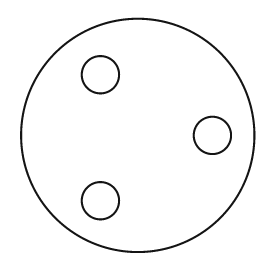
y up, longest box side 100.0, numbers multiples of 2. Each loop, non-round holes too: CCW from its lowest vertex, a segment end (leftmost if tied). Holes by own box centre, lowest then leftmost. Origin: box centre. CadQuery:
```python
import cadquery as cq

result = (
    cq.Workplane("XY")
    .moveTo(0.0, 0.0)
    .circle(50.0)
    .moveTo(-16.0, -28.0)
    .circle(8.0)
    .moveTo(32.0, 0.0)
    .circle(8.0)
    .moveTo(-16.0, 26.0)
    .circle(8.0)
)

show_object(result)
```